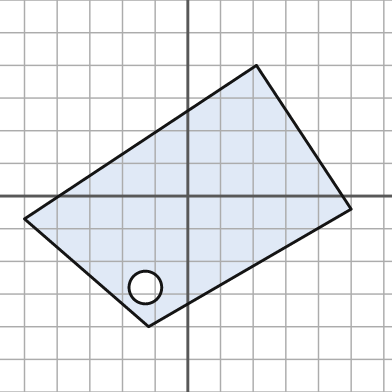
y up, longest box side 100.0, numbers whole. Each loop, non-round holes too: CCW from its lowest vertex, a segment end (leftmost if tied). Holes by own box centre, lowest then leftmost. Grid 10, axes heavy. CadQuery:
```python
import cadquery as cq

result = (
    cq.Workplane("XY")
    .moveTo(-12.0, -40.0)
    .lineTo(50.0, -4.0)
    .lineTo(21.0, 40.0)
    .lineTo(-50.0, -7.0)
    .close()
    .moveTo(-13.0, -28.0)
    .circle(5.0)
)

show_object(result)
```